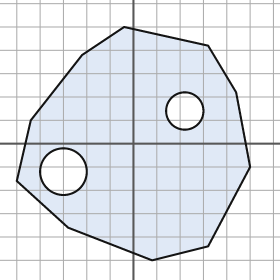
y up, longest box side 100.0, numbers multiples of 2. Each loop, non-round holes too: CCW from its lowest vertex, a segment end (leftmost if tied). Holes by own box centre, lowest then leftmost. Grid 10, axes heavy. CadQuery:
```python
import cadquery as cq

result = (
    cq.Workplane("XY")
    .moveTo(8.0, -50.0)
    .lineTo(32.0, -44.0)
    .lineTo(50.0, -10.0)
    .lineTo(44.0, 22.0)
    .lineTo(32.0, 42.0)
    .lineTo(-4.0, 50.0)
    .lineTo(-22.0, 38.0)
    .lineTo(-44.0, 10.0)
    .lineTo(-50.0, -16.0)
    .lineTo(-28.0, -36.0)
    .close()
    .moveTo(-30.0, -12.0)
    .circle(10.0)
    .moveTo(22.0, 14.0)
    .circle(8.0)
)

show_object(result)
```